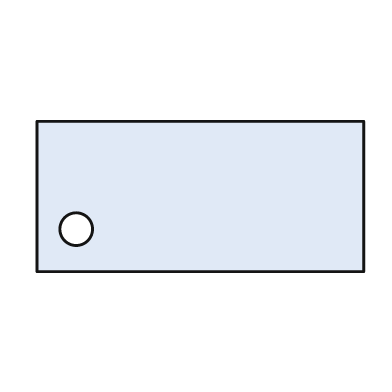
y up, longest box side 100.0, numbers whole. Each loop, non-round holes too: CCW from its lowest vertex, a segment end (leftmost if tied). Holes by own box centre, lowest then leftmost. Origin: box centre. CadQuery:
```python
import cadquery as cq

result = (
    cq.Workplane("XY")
    .moveTo(-50.0, -23.0)
    .lineTo(50.0, -23.0)
    .lineTo(50.0, 23.0)
    .lineTo(-50.0, 23.0)
    .close()
    .moveTo(-38.0, -10.0)
    .circle(5.0)
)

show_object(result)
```